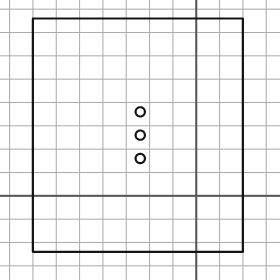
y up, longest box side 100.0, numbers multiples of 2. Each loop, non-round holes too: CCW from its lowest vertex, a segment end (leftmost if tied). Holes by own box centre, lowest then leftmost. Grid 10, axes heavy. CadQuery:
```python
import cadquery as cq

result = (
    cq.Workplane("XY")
    .moveTo(-70.0, -24.0)
    .lineTo(20.0, -24.0)
    .lineTo(20.0, 76.0)
    .lineTo(-70.0, 76.0)
    .close()
    .moveTo(-24.0, 16.0)
    .circle(2.0)
    .moveTo(-24.0, 26.0)
    .circle(2.0)
    .moveTo(-24.0, 36.0)
    .circle(2.0)
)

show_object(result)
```